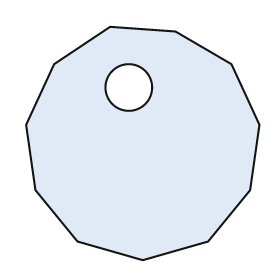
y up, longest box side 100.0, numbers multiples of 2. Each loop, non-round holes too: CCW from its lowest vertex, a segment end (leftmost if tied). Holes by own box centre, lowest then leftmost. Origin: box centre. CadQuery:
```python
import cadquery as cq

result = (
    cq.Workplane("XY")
    .moveTo(0.0, -50.0)
    .lineTo(28.0, -42.0)
    .lineTo(46.0, -20.0)
    .lineTo(50.0, 8.0)
    .lineTo(38.0, 34.0)
    .lineTo(14.0, 48.0)
    .lineTo(-14.0, 50.0)
    .lineTo(-38.0, 34.0)
    .lineTo(-50.0, 8.0)
    .lineTo(-46.0, -20.0)
    .lineTo(-28.0, -42.0)
    .close()
    .moveTo(-6.0, 24.0)
    .circle(10.0)
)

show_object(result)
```